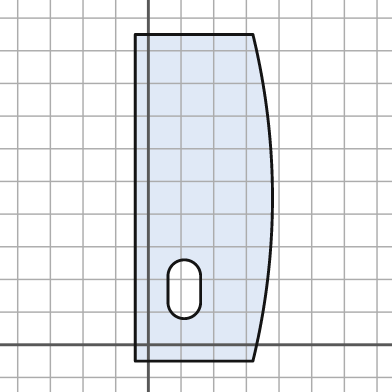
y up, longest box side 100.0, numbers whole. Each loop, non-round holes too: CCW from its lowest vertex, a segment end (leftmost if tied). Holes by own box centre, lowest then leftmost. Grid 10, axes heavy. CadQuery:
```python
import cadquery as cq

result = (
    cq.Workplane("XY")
    .moveTo(-4.0, -5.0)
    .lineTo(32.0, -5.0)
    .threePointArc((38.0, 45.0), (32.0, 95.0))
    .lineTo(-4.0, 95.0)
    .close()
    .moveTo(6.0, 13.0)
    .threePointArc((11.0, 8.0), (16.0, 13.0))
    .lineTo(16.0, 21.0)
    .threePointArc((11.0, 26.0), (6.0, 21.0))
    .close()
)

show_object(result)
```